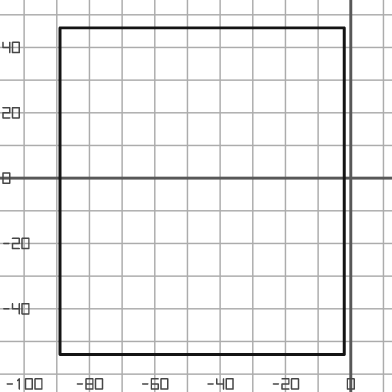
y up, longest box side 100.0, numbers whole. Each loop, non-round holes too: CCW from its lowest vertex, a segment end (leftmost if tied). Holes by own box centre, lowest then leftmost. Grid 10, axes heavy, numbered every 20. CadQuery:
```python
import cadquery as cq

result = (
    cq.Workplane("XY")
    .moveTo(-89.0, -54.0)
    .lineTo(-2.0, -54.0)
    .lineTo(-2.0, 46.0)
    .lineTo(-89.0, 46.0)
    .close()
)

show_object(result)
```